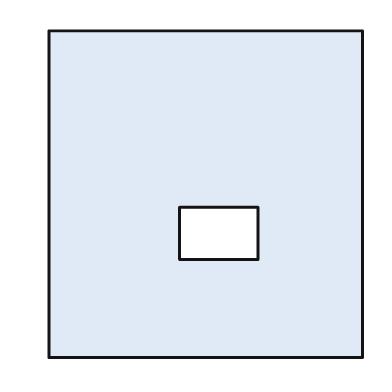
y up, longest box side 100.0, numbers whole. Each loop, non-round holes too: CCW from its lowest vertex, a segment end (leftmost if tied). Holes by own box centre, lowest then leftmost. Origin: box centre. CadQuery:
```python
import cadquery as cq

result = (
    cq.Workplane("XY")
    .moveTo(-48.0, -50.0)
    .lineTo(48.0, -50.0)
    .lineTo(48.0, 50.0)
    .lineTo(-48.0, 50.0)
    .close()
    .moveTo(-8.0, -20.0)
    .lineTo(16.0, -20.0)
    .lineTo(16.0, -4.0)
    .lineTo(-8.0, -4.0)
    .close()
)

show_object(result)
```